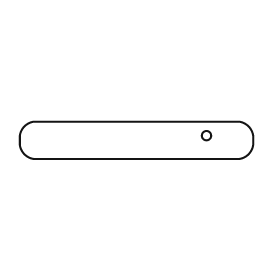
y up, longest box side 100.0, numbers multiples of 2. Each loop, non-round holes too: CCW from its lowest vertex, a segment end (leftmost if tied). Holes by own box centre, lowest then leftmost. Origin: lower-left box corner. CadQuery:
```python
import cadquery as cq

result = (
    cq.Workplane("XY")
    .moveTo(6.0, 0.0)
    .lineTo(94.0, 0.0)
    .threePointArc((98.0, 2.0), (100.0, 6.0))
    .lineTo(100.0, 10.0)
    .threePointArc((98.0, 14.0), (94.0, 16.0))
    .lineTo(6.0, 16.0)
    .threePointArc((2.0, 14.0), (0.0, 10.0))
    .lineTo(0.0, 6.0)
    .threePointArc((2.0, 2.0), (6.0, 0.0))
    .close()
    .moveTo(80.0, 10.0)
    .circle(2.0)
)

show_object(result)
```